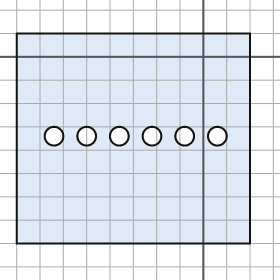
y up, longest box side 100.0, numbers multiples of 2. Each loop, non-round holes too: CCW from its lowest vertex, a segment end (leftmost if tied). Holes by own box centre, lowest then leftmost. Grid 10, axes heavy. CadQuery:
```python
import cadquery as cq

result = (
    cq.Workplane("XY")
    .moveTo(-80.0, -80.0)
    .lineTo(20.0, -80.0)
    .lineTo(20.0, 10.0)
    .lineTo(-80.0, 10.0)
    .close()
    .moveTo(-64.0, -34.0)
    .circle(4.0)
    .moveTo(-50.0, -34.0)
    .circle(4.0)
    .moveTo(-36.0, -34.0)
    .circle(4.0)
    .moveTo(-22.0, -34.0)
    .circle(4.0)
    .moveTo(-8.0, -34.0)
    .circle(4.0)
    .moveTo(6.0, -34.0)
    .circle(4.0)
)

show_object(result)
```